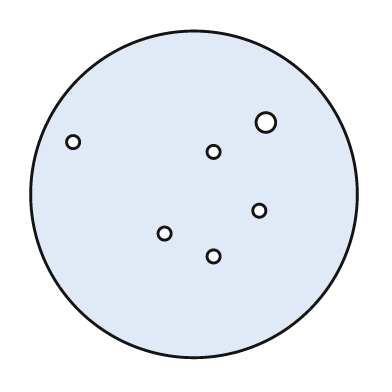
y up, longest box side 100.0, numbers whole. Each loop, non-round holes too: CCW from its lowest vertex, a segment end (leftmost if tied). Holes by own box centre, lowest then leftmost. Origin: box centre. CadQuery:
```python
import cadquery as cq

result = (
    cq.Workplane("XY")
    .moveTo(0.0, 0.0)
    .circle(50.0)
    .moveTo(6.0, -19.0)
    .circle(2.0)
    .moveTo(-9.0, -12.0)
    .circle(2.0)
    .moveTo(20.0, -5.0)
    .circle(2.0)
    .moveTo(6.0, 13.0)
    .circle(2.0)
    .moveTo(-37.0, 16.0)
    .circle(2.0)
    .moveTo(22.0, 22.0)
    .circle(3.0)
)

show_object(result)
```